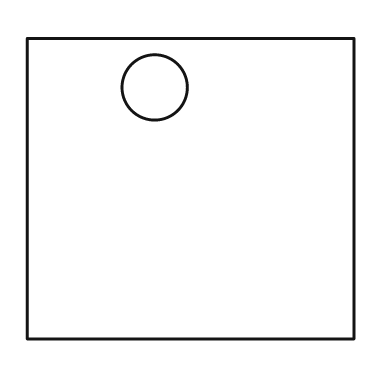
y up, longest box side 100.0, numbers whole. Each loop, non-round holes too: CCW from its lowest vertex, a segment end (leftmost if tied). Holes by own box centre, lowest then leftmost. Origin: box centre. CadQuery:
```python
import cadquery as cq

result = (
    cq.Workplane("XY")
    .moveTo(-50.0, -46.0)
    .lineTo(50.0, -46.0)
    .lineTo(50.0, 46.0)
    .lineTo(-50.0, 46.0)
    .close()
    .moveTo(-11.0, 31.0)
    .circle(10.0)
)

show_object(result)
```